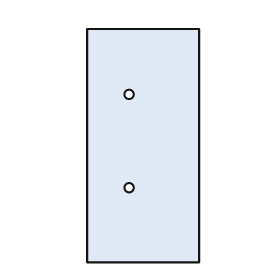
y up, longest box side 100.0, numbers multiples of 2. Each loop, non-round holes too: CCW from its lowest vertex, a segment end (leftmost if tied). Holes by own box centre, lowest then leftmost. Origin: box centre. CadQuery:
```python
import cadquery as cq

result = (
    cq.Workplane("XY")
    .moveTo(-24.0, -50.0)
    .lineTo(24.0, -50.0)
    .lineTo(24.0, 50.0)
    .lineTo(-24.0, 50.0)
    .close()
    .moveTo(-6.0, -18.0)
    .circle(2.0)
    .moveTo(-6.0, 22.0)
    .circle(2.0)
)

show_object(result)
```